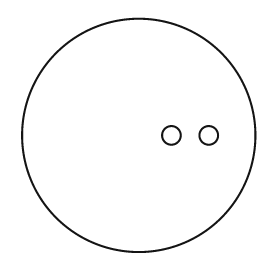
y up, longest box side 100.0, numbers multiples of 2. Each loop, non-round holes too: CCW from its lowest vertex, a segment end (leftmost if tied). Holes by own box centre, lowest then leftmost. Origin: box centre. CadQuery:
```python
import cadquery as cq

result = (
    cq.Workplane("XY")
    .moveTo(0.0, 0.0)
    .circle(50.0)
    .moveTo(14.0, 0.0)
    .circle(4.0)
    .moveTo(30.0, 0.0)
    .circle(4.0)
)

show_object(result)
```